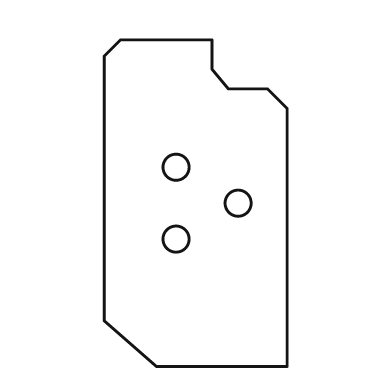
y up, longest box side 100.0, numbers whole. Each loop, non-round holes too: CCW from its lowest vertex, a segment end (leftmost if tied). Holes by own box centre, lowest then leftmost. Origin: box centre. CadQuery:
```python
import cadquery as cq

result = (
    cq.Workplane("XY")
    .moveTo(-12.0, -50.0)
    .lineTo(28.0, -50.0)
    .lineTo(28.0, 29.0)
    .lineTo(22.0, 35.0)
    .lineTo(10.0, 35.0)
    .lineTo(5.0, 41.0)
    .lineTo(5.0, 50.0)
    .lineTo(-23.0, 50.0)
    .lineTo(-28.0, 45.0)
    .lineTo(-28.0, -36.0)
    .close()
    .moveTo(-6.0, -11.0)
    .circle(4.0)
    .moveTo(13.0, 0.0)
    .circle(4.0)
    .moveTo(-6.0, 11.0)
    .circle(4.0)
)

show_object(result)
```